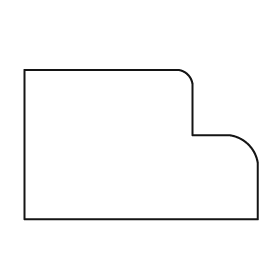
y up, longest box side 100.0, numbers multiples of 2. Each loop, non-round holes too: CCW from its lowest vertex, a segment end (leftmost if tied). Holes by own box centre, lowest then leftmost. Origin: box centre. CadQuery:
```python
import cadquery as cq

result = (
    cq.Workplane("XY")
    .moveTo(-50.0, -32.0)
    .lineTo(50.0, -32.0)
    .lineTo(50.0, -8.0)
    .threePointArc((46.0, 0.0), (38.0, 4.0))
    .lineTo(22.0, 4.0)
    .lineTo(22.0, 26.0)
    .threePointArc((20.0, 30.0), (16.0, 32.0))
    .lineTo(-50.0, 32.0)
    .close()
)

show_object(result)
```